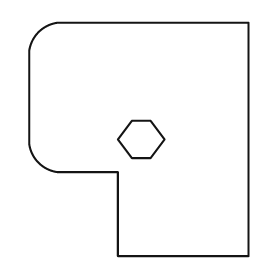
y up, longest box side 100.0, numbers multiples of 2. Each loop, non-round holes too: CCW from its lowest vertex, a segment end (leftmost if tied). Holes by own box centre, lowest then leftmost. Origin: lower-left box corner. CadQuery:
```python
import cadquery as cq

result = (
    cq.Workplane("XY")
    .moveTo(38.0, 0.0)
    .lineTo(94.0, 0.0)
    .lineTo(94.0, 100.0)
    .lineTo(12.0, 100.0)
    .threePointArc((4.0, 96.0), (0.0, 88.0))
    .lineTo(0.0, 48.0)
    .threePointArc((4.0, 40.0), (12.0, 36.0))
    .lineTo(38.0, 36.0)
    .close()
    .moveTo(44.0, 42.0)
    .lineTo(52.0, 42.0)
    .lineTo(58.0, 50.0)
    .lineTo(52.0, 58.0)
    .lineTo(44.0, 58.0)
    .lineTo(38.0, 50.0)
    .close()
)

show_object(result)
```